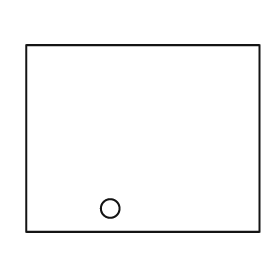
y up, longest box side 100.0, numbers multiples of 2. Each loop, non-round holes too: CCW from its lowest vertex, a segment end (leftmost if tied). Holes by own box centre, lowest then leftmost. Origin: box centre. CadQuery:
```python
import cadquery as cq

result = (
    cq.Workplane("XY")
    .moveTo(-50.0, -40.0)
    .lineTo(50.0, -40.0)
    .lineTo(50.0, 40.0)
    .lineTo(-50.0, 40.0)
    .close()
    .moveTo(-14.0, -30.0)
    .circle(4.0)
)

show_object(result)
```